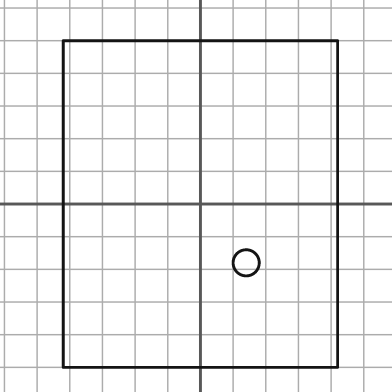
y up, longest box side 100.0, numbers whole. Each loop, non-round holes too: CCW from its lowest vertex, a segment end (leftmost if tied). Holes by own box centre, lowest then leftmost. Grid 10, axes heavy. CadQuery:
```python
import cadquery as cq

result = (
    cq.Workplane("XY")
    .moveTo(-42.0, -50.0)
    .lineTo(42.0, -50.0)
    .lineTo(42.0, 50.0)
    .lineTo(-42.0, 50.0)
    .close()
    .moveTo(14.0, -18.0)
    .circle(4.0)
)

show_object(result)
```